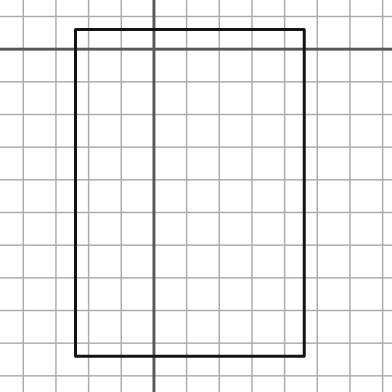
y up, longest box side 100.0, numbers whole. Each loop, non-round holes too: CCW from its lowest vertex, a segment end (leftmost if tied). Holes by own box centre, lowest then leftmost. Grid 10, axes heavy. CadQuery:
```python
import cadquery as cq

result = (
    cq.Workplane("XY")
    .moveTo(-24.0, -94.0)
    .lineTo(46.0, -94.0)
    .lineTo(46.0, 6.0)
    .lineTo(-24.0, 6.0)
    .close()
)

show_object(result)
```